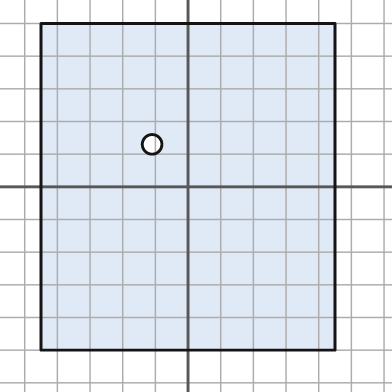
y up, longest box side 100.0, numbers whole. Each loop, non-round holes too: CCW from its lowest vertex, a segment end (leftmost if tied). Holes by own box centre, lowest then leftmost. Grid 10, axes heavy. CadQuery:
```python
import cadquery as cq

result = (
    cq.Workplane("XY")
    .moveTo(-45.0, -50.0)
    .lineTo(45.0, -50.0)
    .lineTo(45.0, 50.0)
    .lineTo(-45.0, 50.0)
    .close()
    .moveTo(-11.0, 13.0)
    .circle(3.0)
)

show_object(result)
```